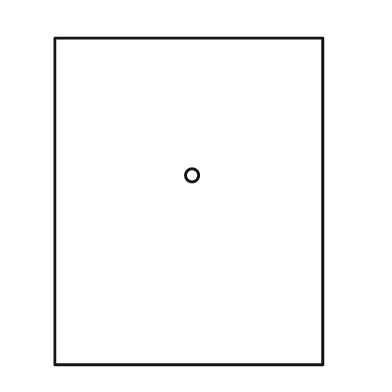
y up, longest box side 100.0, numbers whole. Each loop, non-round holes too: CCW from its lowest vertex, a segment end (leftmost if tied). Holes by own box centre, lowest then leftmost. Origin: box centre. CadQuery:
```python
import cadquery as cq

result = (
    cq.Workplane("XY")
    .moveTo(-41.0, -50.0)
    .lineTo(41.0, -50.0)
    .lineTo(41.0, 50.0)
    .lineTo(-41.0, 50.0)
    .close()
    .moveTo(1.0, 8.0)
    .circle(2.0)
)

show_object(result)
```